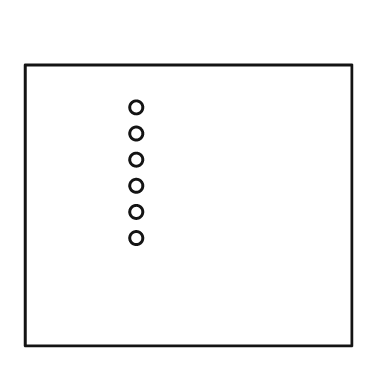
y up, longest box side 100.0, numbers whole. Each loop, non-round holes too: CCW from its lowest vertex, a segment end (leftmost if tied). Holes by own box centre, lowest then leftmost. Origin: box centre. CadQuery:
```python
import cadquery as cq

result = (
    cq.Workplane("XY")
    .moveTo(-50.0, -43.0)
    .lineTo(50.0, -43.0)
    .lineTo(50.0, 43.0)
    .lineTo(-50.0, 43.0)
    .close()
    .moveTo(-16.0, -10.0)
    .circle(2.0)
    .moveTo(-16.0, -2.0)
    .circle(2.0)
    .moveTo(-16.0, 6.0)
    .circle(2.0)
    .moveTo(-16.0, 14.0)
    .circle(2.0)
    .moveTo(-16.0, 22.0)
    .circle(2.0)
    .moveTo(-16.0, 30.0)
    .circle(2.0)
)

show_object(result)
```